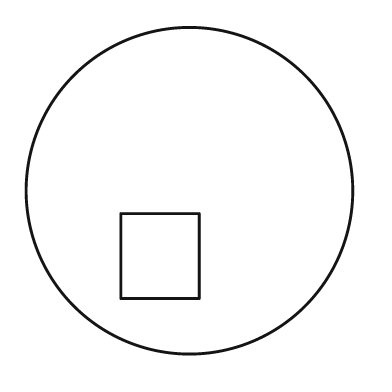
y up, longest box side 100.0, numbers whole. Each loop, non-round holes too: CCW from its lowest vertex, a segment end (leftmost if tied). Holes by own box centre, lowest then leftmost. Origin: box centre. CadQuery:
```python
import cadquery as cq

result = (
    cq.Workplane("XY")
    .moveTo(0.0, 0.0)
    .circle(50.0)
    .moveTo(-21.0, -33.0)
    .lineTo(3.0, -33.0)
    .lineTo(3.0, -7.0)
    .lineTo(-21.0, -7.0)
    .close()
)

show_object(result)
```